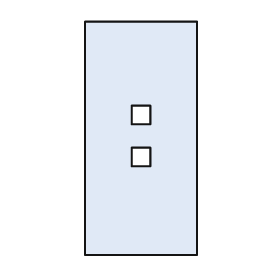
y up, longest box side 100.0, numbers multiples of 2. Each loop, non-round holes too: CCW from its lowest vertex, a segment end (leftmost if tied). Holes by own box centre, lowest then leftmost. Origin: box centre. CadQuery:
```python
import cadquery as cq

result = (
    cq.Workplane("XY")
    .moveTo(-24.0, -50.0)
    .lineTo(24.0, -50.0)
    .lineTo(24.0, 50.0)
    .lineTo(-24.0, 50.0)
    .close()
    .moveTo(-4.0, -12.0)
    .lineTo(4.0, -12.0)
    .lineTo(4.0, -4.0)
    .lineTo(-4.0, -4.0)
    .close()
    .moveTo(-4.0, 6.0)
    .lineTo(4.0, 6.0)
    .lineTo(4.0, 14.0)
    .lineTo(-4.0, 14.0)
    .close()
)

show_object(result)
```